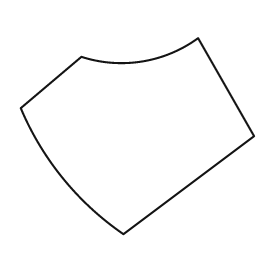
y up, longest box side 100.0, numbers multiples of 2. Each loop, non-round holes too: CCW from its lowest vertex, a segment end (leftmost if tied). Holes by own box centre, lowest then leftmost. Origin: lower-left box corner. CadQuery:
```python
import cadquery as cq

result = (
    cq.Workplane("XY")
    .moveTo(44.0, 0.0)
    .lineTo(100.0, 42.0)
    .lineTo(76.0, 84.0)
    .threePointArc((52.0, 74.0), (26.0, 76.0))
    .lineTo(0.0, 54.0)
    .threePointArc((18.0, 24.0), (44.0, 0.0))
    .close()
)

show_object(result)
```